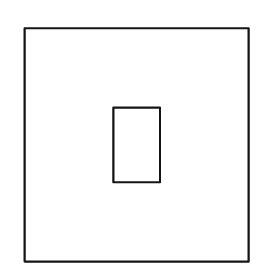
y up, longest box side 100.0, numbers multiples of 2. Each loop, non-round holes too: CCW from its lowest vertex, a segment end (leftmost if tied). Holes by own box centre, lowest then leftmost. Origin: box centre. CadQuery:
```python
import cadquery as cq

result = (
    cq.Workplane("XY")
    .moveTo(-48.0, -50.0)
    .lineTo(48.0, -50.0)
    .lineTo(48.0, 50.0)
    .lineTo(-48.0, 50.0)
    .close()
    .moveTo(-10.0, -16.0)
    .lineTo(10.0, -16.0)
    .lineTo(10.0, 16.0)
    .lineTo(-10.0, 16.0)
    .close()
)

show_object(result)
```